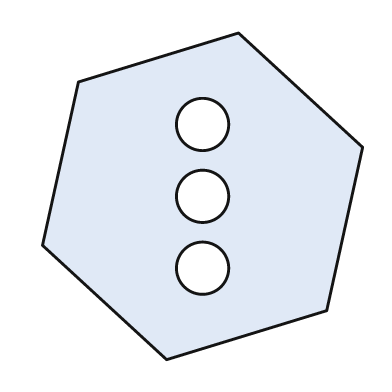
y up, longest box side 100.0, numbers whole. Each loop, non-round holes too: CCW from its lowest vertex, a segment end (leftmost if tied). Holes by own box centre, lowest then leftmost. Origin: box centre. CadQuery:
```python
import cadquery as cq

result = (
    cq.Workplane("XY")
    .moveTo(-11.0, -50.0)
    .lineTo(38.0, -35.0)
    .lineTo(49.0, 15.0)
    .lineTo(11.0, 50.0)
    .lineTo(-38.0, 35.0)
    .lineTo(-49.0, -15.0)
    .close()
    .moveTo(0.0, -22.0)
    .circle(8.0)
    .moveTo(0.0, 0.0)
    .circle(8.0)
    .moveTo(0.0, 22.0)
    .circle(8.0)
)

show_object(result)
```